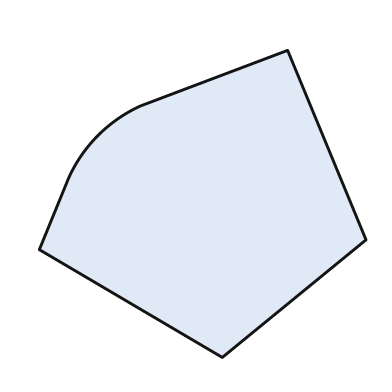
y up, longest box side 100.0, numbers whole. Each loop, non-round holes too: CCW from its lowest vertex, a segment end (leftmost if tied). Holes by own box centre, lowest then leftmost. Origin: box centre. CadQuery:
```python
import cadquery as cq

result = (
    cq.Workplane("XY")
    .moveTo(6.0, -47.0)
    .lineTo(50.0, -11.0)
    .lineTo(26.0, 47.0)
    .lineTo(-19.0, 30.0)
    .threePointArc((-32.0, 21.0), (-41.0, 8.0))
    .lineTo(-50.0, -14.0)
    .close()
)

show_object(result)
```